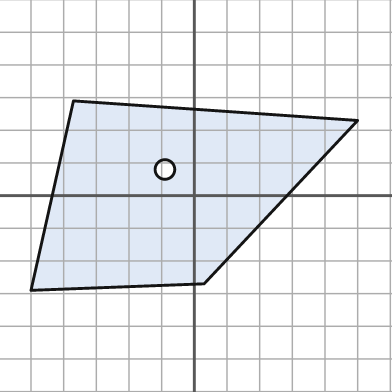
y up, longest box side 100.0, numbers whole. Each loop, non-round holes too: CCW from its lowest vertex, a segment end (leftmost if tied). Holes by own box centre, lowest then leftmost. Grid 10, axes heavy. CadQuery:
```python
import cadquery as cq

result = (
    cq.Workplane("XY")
    .moveTo(-50.0, -29.0)
    .lineTo(3.0, -27.0)
    .lineTo(50.0, 23.0)
    .lineTo(-37.0, 29.0)
    .close()
    .moveTo(-9.0, 8.0)
    .circle(3.0)
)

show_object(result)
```